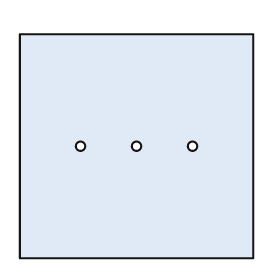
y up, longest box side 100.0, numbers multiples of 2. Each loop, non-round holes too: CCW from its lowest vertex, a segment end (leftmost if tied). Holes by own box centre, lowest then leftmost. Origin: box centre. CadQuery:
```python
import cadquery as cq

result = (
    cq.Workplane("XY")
    .moveTo(-50.0, -48.0)
    .lineTo(50.0, -48.0)
    .lineTo(50.0, 48.0)
    .lineTo(-50.0, 48.0)
    .close()
    .moveTo(-24.0, 0.0)
    .circle(2.0)
    .moveTo(0.0, 0.0)
    .circle(2.0)
    .moveTo(24.0, 0.0)
    .circle(2.0)
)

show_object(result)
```